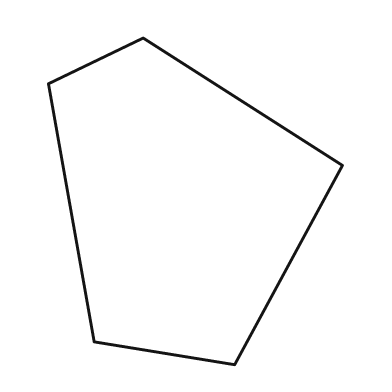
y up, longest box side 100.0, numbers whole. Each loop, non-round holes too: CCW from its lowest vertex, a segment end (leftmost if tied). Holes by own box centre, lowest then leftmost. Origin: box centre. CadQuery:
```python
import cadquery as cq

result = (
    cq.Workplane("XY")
    .moveTo(12.0, -50.0)
    .lineTo(45.0, 11.0)
    .lineTo(-16.0, 50.0)
    .lineTo(-45.0, 36.0)
    .lineTo(-31.0, -43.0)
    .close()
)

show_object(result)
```